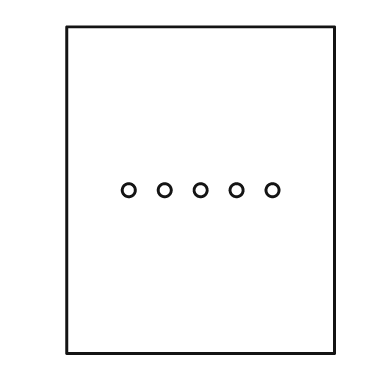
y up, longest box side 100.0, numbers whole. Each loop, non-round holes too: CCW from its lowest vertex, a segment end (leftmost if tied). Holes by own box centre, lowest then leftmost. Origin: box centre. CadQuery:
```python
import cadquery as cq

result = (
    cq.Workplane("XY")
    .moveTo(-41.0, -50.0)
    .lineTo(41.0, -50.0)
    .lineTo(41.0, 50.0)
    .lineTo(-41.0, 50.0)
    .close()
    .moveTo(-22.0, 0.0)
    .circle(2.0)
    .moveTo(-11.0, 0.0)
    .circle(2.0)
    .moveTo(0.0, 0.0)
    .circle(2.0)
    .moveTo(11.0, 0.0)
    .circle(2.0)
    .moveTo(22.0, 0.0)
    .circle(2.0)
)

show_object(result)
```